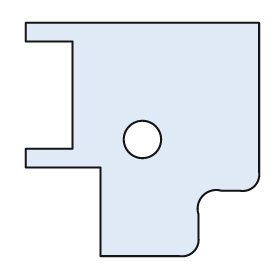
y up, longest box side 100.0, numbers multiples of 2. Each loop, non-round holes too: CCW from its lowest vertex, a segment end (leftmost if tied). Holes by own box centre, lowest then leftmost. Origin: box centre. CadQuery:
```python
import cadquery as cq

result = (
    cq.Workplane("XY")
    .moveTo(-18.0, -50.0)
    .lineTo(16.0, -50.0)
    .threePointArc((22.0, -48.0), (24.0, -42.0))
    .lineTo(24.0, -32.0)
    .threePointArc((26.0, -24.0), (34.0, -22.0))
    .lineTo(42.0, -22.0)
    .threePointArc((48.0, -20.0), (50.0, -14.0))
    .lineTo(50.0, 50.0)
    .lineTo(-50.0, 50.0)
    .lineTo(-50.0, 42.0)
    .lineTo(-30.0, 42.0)
    .lineTo(-30.0, -4.0)
    .lineTo(-50.0, -4.0)
    .lineTo(-50.0, -12.0)
    .lineTo(-18.0, -12.0)
    .close()
    .moveTo(0.0, 0.0)
    .circle(8.0)
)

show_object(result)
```